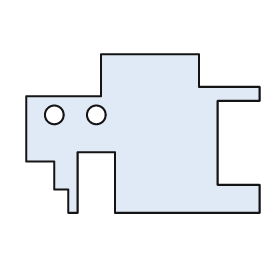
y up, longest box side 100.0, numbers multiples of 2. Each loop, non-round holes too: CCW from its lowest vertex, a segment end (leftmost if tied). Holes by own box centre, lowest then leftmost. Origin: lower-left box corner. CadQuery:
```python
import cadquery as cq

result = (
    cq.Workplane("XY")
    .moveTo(18.0, 0.0)
    .lineTo(22.0, 0.0)
    .lineTo(22.0, 26.0)
    .lineTo(38.0, 26.0)
    .lineTo(38.0, 0.0)
    .lineTo(100.0, 0.0)
    .lineTo(100.0, 12.0)
    .lineTo(82.0, 12.0)
    .lineTo(82.0, 48.0)
    .lineTo(100.0, 48.0)
    .lineTo(100.0, 54.0)
    .lineTo(74.0, 54.0)
    .lineTo(74.0, 68.0)
    .lineTo(32.0, 68.0)
    .lineTo(32.0, 50.0)
    .lineTo(0.0, 50.0)
    .lineTo(0.0, 22.0)
    .lineTo(12.0, 22.0)
    .lineTo(12.0, 10.0)
    .lineTo(18.0, 10.0)
    .close()
    .moveTo(12.0, 42.0)
    .circle(4.0)
    .moveTo(30.0, 42.0)
    .circle(4.0)
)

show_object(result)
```